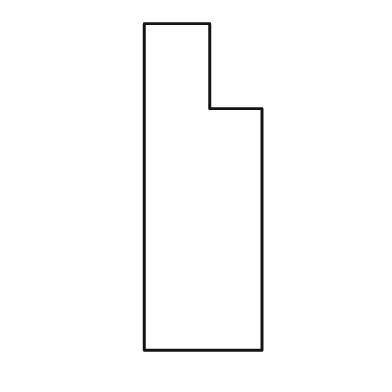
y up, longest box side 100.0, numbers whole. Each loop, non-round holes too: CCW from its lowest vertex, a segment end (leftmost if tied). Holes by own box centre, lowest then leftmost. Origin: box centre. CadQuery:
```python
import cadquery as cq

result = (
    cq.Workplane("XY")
    .moveTo(-18.0, -50.0)
    .lineTo(18.0, -50.0)
    .lineTo(18.0, 24.0)
    .lineTo(2.0, 24.0)
    .lineTo(2.0, 50.0)
    .lineTo(-18.0, 50.0)
    .close()
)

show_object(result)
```